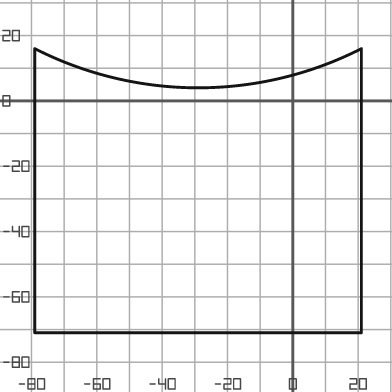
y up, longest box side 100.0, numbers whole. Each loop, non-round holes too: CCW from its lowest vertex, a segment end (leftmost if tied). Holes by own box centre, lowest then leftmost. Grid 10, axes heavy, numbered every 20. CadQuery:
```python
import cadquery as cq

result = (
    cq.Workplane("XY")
    .moveTo(-79.0, -71.0)
    .lineTo(21.0, -71.0)
    .lineTo(21.0, 16.0)
    .threePointArc((-29.0, 4.0), (-79.0, 16.0))
    .close()
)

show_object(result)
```